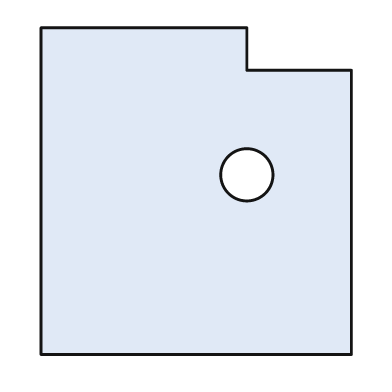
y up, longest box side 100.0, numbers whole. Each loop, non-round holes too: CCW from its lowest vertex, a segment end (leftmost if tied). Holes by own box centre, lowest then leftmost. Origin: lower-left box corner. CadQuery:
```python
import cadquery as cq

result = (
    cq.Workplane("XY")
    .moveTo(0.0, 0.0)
    .lineTo(95.0, 0.0)
    .lineTo(95.0, 87.0)
    .lineTo(63.0, 87.0)
    .lineTo(63.0, 100.0)
    .lineTo(0.0, 100.0)
    .close()
    .moveTo(63.0, 55.0)
    .circle(8.0)
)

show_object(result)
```